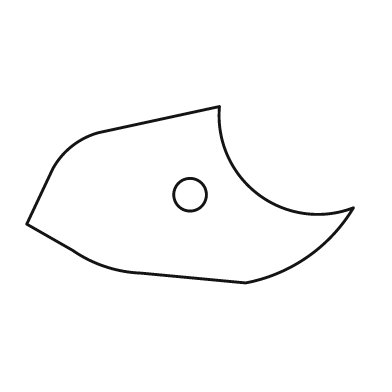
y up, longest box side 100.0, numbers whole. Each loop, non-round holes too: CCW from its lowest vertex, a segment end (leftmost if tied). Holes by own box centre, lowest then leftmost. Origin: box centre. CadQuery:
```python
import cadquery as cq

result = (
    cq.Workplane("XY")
    .moveTo(17.0, -27.0)
    .threePointArc((36.0, -19.0), (50.0, -4.0))
    .threePointArc((21.0, 0.0), (9.0, 27.0))
    .lineTo(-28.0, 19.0)
    .threePointArc((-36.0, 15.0), (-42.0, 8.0))
    .lineTo(-50.0, -9.0)
    .lineTo(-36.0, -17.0)
    .threePointArc((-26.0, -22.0), (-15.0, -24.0))
    .close()
    .moveTo(0.0, 0.0)
    .circle(5.0)
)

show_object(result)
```